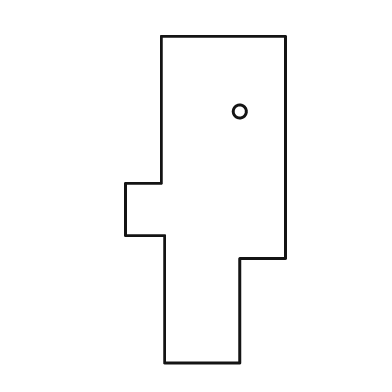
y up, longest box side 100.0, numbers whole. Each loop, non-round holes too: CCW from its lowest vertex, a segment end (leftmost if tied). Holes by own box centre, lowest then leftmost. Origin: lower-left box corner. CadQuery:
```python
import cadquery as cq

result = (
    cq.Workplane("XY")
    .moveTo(12.0, 0.0)
    .lineTo(35.0, 0.0)
    .lineTo(35.0, 32.0)
    .lineTo(49.0, 32.0)
    .lineTo(49.0, 100.0)
    .lineTo(11.0, 100.0)
    .lineTo(11.0, 55.0)
    .lineTo(0.0, 55.0)
    .lineTo(0.0, 39.0)
    .lineTo(12.0, 39.0)
    .close()
    .moveTo(35.0, 77.0)
    .circle(2.0)
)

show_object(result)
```